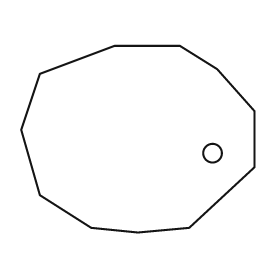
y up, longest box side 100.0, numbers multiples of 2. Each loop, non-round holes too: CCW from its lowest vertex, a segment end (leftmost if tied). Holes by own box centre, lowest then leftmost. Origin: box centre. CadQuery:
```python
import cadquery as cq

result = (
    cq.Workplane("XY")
    .moveTo(0.0, -40.0)
    .lineTo(22.0, -38.0)
    .lineTo(50.0, -12.0)
    .lineTo(50.0, 12.0)
    .lineTo(34.0, 30.0)
    .lineTo(18.0, 40.0)
    .lineTo(-10.0, 40.0)
    .lineTo(-42.0, 28.0)
    .lineTo(-50.0, 4.0)
    .lineTo(-42.0, -24.0)
    .lineTo(-20.0, -38.0)
    .close()
    .moveTo(32.0, -6.0)
    .circle(4.0)
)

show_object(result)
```